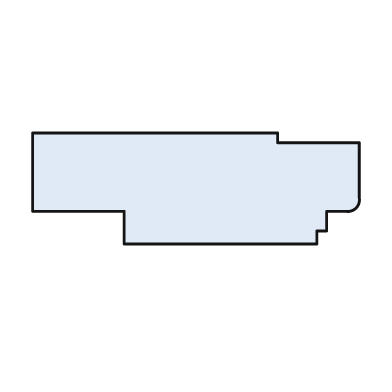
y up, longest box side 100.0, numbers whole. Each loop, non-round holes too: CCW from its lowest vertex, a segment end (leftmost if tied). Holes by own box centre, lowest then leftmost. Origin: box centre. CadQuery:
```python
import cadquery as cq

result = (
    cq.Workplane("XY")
    .moveTo(-22.0, -17.0)
    .lineTo(37.0, -17.0)
    .lineTo(37.0, -13.0)
    .lineTo(40.0, -13.0)
    .lineTo(40.0, -7.0)
    .lineTo(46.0, -7.0)
    .threePointArc((49.0, -6.0), (50.0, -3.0))
    .lineTo(50.0, 14.0)
    .lineTo(25.0, 14.0)
    .lineTo(25.0, 17.0)
    .lineTo(-50.0, 17.0)
    .lineTo(-50.0, -7.0)
    .lineTo(-22.0, -7.0)
    .close()
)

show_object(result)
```